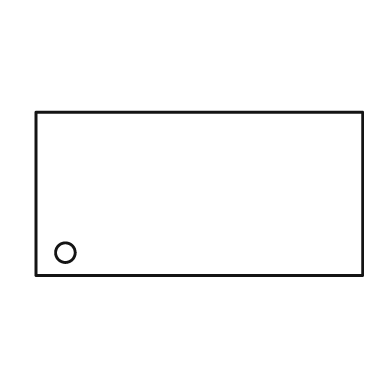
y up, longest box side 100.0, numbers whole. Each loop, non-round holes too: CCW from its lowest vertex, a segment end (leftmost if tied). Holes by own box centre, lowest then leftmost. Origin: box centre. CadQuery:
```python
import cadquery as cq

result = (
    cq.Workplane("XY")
    .moveTo(-50.0, -25.0)
    .lineTo(50.0, -25.0)
    .lineTo(50.0, 25.0)
    .lineTo(-50.0, 25.0)
    .close()
    .moveTo(-41.0, -18.0)
    .circle(3.0)
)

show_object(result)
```